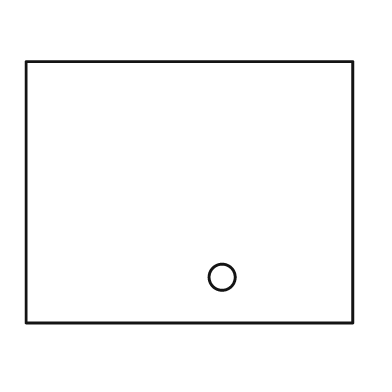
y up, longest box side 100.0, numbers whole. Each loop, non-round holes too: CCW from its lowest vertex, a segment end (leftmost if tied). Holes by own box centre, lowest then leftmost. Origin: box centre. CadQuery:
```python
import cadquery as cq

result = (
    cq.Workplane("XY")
    .moveTo(-50.0, -40.0)
    .lineTo(50.0, -40.0)
    .lineTo(50.0, 40.0)
    .lineTo(-50.0, 40.0)
    .close()
    .moveTo(10.0, -26.0)
    .circle(4.0)
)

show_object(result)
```